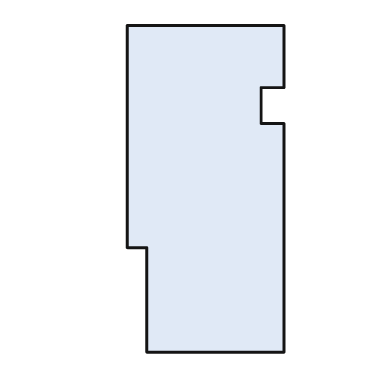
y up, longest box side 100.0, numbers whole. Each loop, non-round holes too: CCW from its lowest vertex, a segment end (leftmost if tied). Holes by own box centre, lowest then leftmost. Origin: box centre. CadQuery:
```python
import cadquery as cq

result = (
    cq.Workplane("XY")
    .moveTo(-18.0, -50.0)
    .lineTo(24.0, -50.0)
    .lineTo(24.0, 20.0)
    .lineTo(17.0, 20.0)
    .lineTo(17.0, 31.0)
    .lineTo(24.0, 31.0)
    .lineTo(24.0, 50.0)
    .lineTo(-24.0, 50.0)
    .lineTo(-24.0, -18.0)
    .lineTo(-18.0, -18.0)
    .close()
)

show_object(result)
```